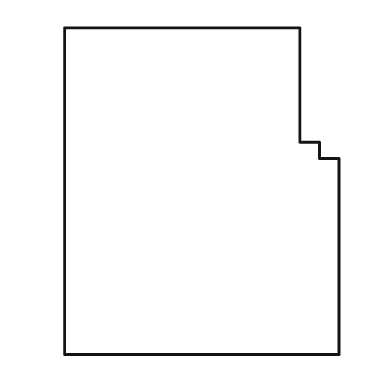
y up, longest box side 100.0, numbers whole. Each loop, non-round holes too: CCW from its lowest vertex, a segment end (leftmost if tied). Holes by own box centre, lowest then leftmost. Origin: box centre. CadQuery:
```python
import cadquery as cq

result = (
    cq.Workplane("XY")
    .moveTo(-42.0, -50.0)
    .lineTo(42.0, -50.0)
    .lineTo(42.0, 10.0)
    .lineTo(36.0, 10.0)
    .lineTo(36.0, 15.0)
    .lineTo(30.0, 15.0)
    .lineTo(30.0, 50.0)
    .lineTo(-42.0, 50.0)
    .close()
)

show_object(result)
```